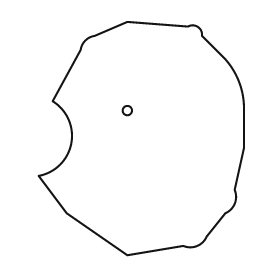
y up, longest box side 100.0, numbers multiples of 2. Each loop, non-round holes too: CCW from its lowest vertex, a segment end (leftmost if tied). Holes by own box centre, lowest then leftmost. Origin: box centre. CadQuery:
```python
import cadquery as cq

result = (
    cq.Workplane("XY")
    .moveTo(-6.0, -50.0)
    .lineTo(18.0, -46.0)
    .threePointArc((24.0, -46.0), (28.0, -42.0))
    .lineTo(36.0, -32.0)
    .threePointArc((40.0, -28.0), (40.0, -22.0))
    .lineTo(44.0, -4.0)
    .lineTo(44.0, 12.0)
    .threePointArc((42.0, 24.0), (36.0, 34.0))
    .lineTo(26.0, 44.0)
    .threePointArc((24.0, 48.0), (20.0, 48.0))
    .lineTo(-6.0, 50.0)
    .lineTo(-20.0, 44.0)
    .threePointArc((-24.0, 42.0), (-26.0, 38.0))
    .lineTo(-38.0, 16.0)
    .threePointArc((-30.0, -2.0), (-44.0, -16.0))
    .lineTo(-32.0, -32.0)
    .close()
    .moveTo(-6.0, 12.0)
    .circle(2.0)
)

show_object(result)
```